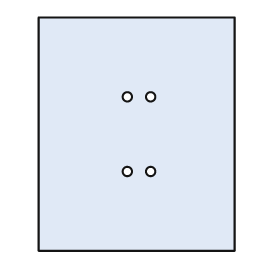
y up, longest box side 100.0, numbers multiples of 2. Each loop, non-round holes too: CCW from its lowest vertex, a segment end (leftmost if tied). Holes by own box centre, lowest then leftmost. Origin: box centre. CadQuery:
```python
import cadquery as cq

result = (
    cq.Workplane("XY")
    .moveTo(-42.0, -50.0)
    .lineTo(42.0, -50.0)
    .lineTo(42.0, 50.0)
    .lineTo(-42.0, 50.0)
    .close()
    .moveTo(-4.0, -16.0)
    .circle(2.0)
    .moveTo(6.0, -16.0)
    .circle(2.0)
    .moveTo(-4.0, 16.0)
    .circle(2.0)
    .moveTo(6.0, 16.0)
    .circle(2.0)
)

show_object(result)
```